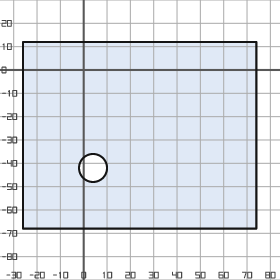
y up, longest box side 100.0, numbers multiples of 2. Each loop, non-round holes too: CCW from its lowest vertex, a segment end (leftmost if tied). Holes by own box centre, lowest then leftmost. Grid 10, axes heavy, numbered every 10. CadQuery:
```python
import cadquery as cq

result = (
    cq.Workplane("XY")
    .moveTo(-26.0, -68.0)
    .lineTo(74.0, -68.0)
    .lineTo(74.0, 12.0)
    .lineTo(-26.0, 12.0)
    .close()
    .moveTo(4.0, -42.0)
    .circle(6.0)
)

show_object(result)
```